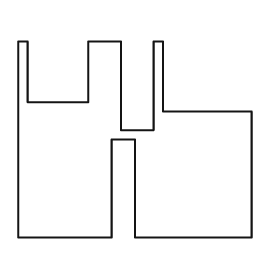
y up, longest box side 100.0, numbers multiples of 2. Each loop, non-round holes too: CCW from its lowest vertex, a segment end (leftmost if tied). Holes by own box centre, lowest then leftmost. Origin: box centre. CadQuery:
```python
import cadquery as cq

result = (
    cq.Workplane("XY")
    .moveTo(-50.0, -42.0)
    .lineTo(-10.0, -42.0)
    .lineTo(-10.0, 0.0)
    .lineTo(0.0, 0.0)
    .lineTo(0.0, -42.0)
    .lineTo(50.0, -42.0)
    .lineTo(50.0, 12.0)
    .lineTo(12.0, 12.0)
    .lineTo(12.0, 42.0)
    .lineTo(8.0, 42.0)
    .lineTo(8.0, 4.0)
    .lineTo(-6.0, 4.0)
    .lineTo(-6.0, 42.0)
    .lineTo(-20.0, 42.0)
    .lineTo(-20.0, 16.0)
    .lineTo(-46.0, 16.0)
    .lineTo(-46.0, 42.0)
    .lineTo(-50.0, 42.0)
    .close()
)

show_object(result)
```